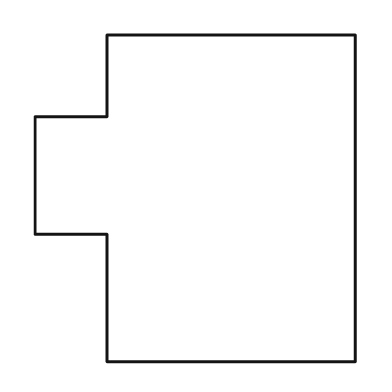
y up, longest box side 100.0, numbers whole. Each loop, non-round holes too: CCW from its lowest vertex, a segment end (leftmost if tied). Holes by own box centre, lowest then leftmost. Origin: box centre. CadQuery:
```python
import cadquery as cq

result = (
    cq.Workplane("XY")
    .moveTo(-27.0, -50.0)
    .lineTo(49.0, -50.0)
    .lineTo(49.0, 50.0)
    .lineTo(-27.0, 50.0)
    .lineTo(-27.0, 25.0)
    .lineTo(-49.0, 25.0)
    .lineTo(-49.0, -11.0)
    .lineTo(-27.0, -11.0)
    .close()
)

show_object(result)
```